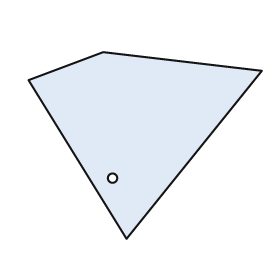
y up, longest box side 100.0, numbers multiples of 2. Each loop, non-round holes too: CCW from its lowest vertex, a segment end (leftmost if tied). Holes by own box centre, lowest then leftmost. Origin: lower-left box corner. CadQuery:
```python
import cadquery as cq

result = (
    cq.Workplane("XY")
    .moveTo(42.0, 0.0)
    .lineTo(100.0, 72.0)
    .lineTo(32.0, 80.0)
    .lineTo(0.0, 68.0)
    .close()
    .moveTo(36.0, 26.0)
    .circle(2.0)
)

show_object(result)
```